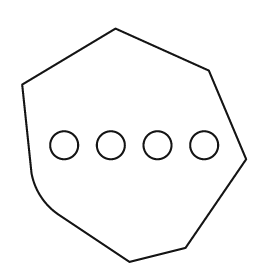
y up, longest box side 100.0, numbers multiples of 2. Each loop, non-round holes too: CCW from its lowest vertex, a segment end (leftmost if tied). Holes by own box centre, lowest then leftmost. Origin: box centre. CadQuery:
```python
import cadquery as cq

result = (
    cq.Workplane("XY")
    .moveTo(-2.0, -50.0)
    .lineTo(22.0, -44.0)
    .lineTo(48.0, -6.0)
    .lineTo(32.0, 32.0)
    .lineTo(-8.0, 50.0)
    .lineTo(-48.0, 26.0)
    .lineTo(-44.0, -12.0)
    .threePointArc((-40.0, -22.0), (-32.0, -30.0))
    .close()
    .moveTo(-30.0, 0.0)
    .circle(6.0)
    .moveTo(-10.0, 0.0)
    .circle(6.0)
    .moveTo(10.0, 0.0)
    .circle(6.0)
    .moveTo(30.0, 0.0)
    .circle(6.0)
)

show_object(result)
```